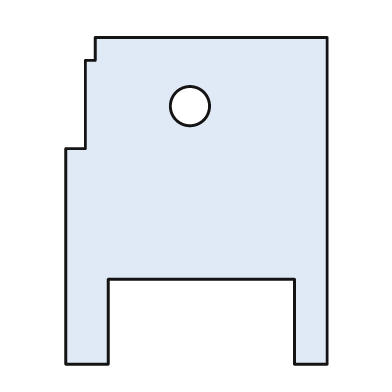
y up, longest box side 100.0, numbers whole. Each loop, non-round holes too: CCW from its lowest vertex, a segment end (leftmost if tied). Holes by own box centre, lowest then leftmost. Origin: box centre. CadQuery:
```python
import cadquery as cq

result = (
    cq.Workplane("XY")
    .moveTo(-40.0, -50.0)
    .lineTo(-27.0, -50.0)
    .lineTo(-27.0, -24.0)
    .lineTo(30.0, -24.0)
    .lineTo(30.0, -50.0)
    .lineTo(40.0, -50.0)
    .lineTo(40.0, 50.0)
    .lineTo(-31.0, 50.0)
    .lineTo(-31.0, 43.0)
    .lineTo(-34.0, 43.0)
    .lineTo(-34.0, 16.0)
    .lineTo(-40.0, 16.0)
    .close()
    .moveTo(-2.0, 29.0)
    .circle(6.0)
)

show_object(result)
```